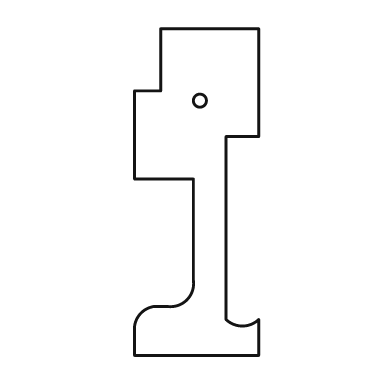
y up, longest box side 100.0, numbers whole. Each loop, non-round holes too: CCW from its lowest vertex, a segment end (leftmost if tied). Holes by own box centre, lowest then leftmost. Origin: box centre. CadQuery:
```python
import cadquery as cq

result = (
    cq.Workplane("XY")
    .moveTo(-19.0, -50.0)
    .lineTo(19.0, -50.0)
    .lineTo(19.0, -39.0)
    .threePointArc((14.0, -41.0), (9.0, -39.0))
    .lineTo(9.0, 17.0)
    .lineTo(19.0, 17.0)
    .lineTo(19.0, 50.0)
    .lineTo(-11.0, 50.0)
    .lineTo(-11.0, 31.0)
    .lineTo(-19.0, 31.0)
    .lineTo(-19.0, 4.0)
    .lineTo(-1.0, 4.0)
    .lineTo(-1.0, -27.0)
    .threePointArc((-3.0, -33.0), (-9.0, -35.0))
    .lineTo(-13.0, -35.0)
    .threePointArc((-17.0, -37.0), (-19.0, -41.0))
    .close()
    .moveTo(1.0, 28.0)
    .circle(2.0)
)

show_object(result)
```